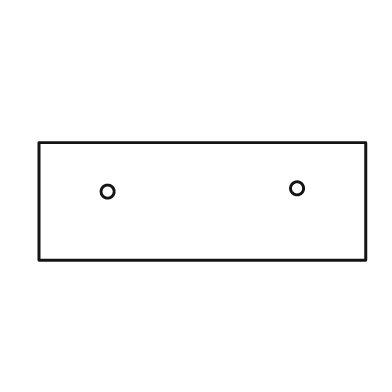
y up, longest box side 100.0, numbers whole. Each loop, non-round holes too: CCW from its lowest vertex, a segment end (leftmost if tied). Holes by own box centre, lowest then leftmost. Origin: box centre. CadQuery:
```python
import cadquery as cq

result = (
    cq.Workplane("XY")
    .moveTo(-50.0, -18.0)
    .lineTo(50.0, -18.0)
    .lineTo(50.0, 18.0)
    .lineTo(-50.0, 18.0)
    .close()
    .moveTo(-29.0, 3.0)
    .circle(2.0)
    .moveTo(29.0, 4.0)
    .circle(2.0)
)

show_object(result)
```